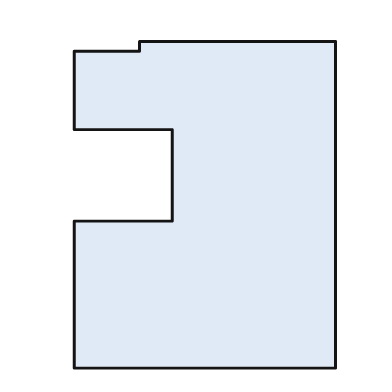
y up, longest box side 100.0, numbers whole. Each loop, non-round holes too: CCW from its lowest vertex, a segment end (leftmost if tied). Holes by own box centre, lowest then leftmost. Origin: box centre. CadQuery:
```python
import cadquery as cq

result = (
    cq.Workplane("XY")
    .moveTo(-40.0, -50.0)
    .lineTo(40.0, -50.0)
    .lineTo(40.0, 50.0)
    .lineTo(-20.0, 50.0)
    .lineTo(-20.0, 47.0)
    .lineTo(-40.0, 47.0)
    .lineTo(-40.0, 23.0)
    .lineTo(-10.0, 23.0)
    .lineTo(-10.0, -5.0)
    .lineTo(-40.0, -5.0)
    .close()
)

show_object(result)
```